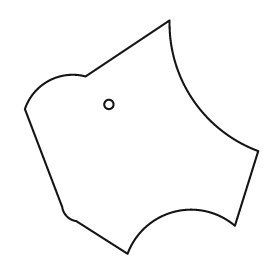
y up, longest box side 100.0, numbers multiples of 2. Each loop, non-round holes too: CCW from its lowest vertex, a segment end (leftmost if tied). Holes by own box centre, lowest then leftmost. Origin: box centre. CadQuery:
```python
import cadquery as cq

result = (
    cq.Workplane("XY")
    .moveTo(-6.0, -50.0)
    .threePointArc((14.0, -32.0), (40.0, -38.0))
    .lineTo(50.0, -6.0)
    .threePointArc((22.0, 16.0), (12.0, 50.0))
    .lineTo(-24.0, 26.0)
    .threePointArc((-40.0, 24.0), (-50.0, 12.0))
    .lineTo(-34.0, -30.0)
    .threePointArc((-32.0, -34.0), (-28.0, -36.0))
    .close()
    .moveTo(-14.0, 14.0)
    .circle(2.0)
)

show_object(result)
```